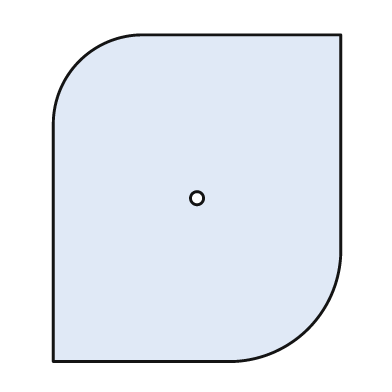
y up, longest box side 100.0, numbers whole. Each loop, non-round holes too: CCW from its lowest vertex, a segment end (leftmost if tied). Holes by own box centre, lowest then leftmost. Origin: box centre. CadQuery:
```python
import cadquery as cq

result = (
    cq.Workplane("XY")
    .moveTo(-44.0, -50.0)
    .lineTo(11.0, -50.0)
    .threePointArc((34.0, -40.0), (44.0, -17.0))
    .lineTo(44.0, 50.0)
    .lineTo(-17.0, 50.0)
    .threePointArc((-36.0, 42.0), (-44.0, 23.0))
    .close()
    .moveTo(0.0, 0.0)
    .circle(2.0)
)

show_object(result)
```